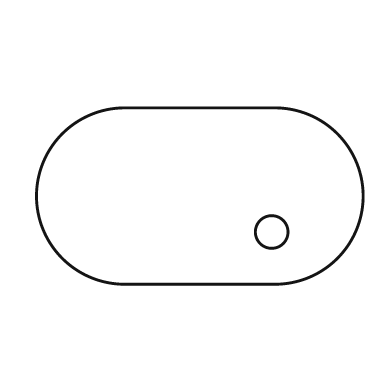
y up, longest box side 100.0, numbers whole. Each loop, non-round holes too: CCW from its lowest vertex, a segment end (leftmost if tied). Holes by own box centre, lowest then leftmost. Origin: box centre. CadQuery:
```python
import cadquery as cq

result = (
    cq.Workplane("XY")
    .moveTo(-23.0, -27.0)
    .lineTo(23.0, -27.0)
    .threePointArc((50.0, 0.0), (23.0, 27.0))
    .lineTo(-23.0, 27.0)
    .threePointArc((-50.0, 0.0), (-23.0, -27.0))
    .close()
    .moveTo(22.0, -11.0)
    .circle(5.0)
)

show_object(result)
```